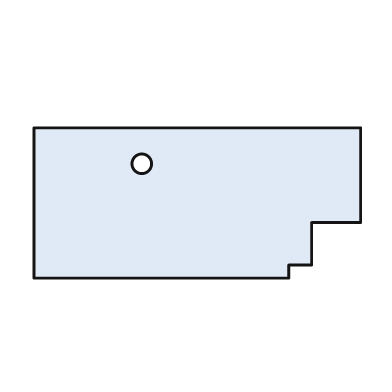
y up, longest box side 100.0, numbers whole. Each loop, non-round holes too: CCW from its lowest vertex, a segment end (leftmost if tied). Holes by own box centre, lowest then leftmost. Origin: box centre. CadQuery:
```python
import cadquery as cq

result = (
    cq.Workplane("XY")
    .moveTo(-50.0, -23.0)
    .lineTo(28.0, -23.0)
    .lineTo(28.0, -19.0)
    .lineTo(35.0, -19.0)
    .lineTo(35.0, -6.0)
    .lineTo(50.0, -6.0)
    .lineTo(50.0, 23.0)
    .lineTo(-50.0, 23.0)
    .close()
    .moveTo(-17.0, 12.0)
    .circle(3.0)
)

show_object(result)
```